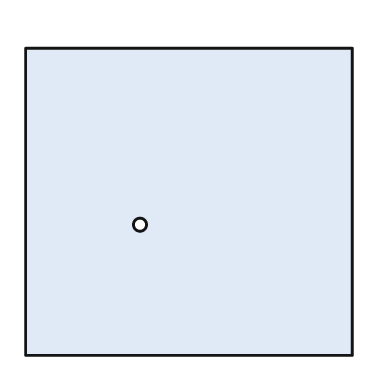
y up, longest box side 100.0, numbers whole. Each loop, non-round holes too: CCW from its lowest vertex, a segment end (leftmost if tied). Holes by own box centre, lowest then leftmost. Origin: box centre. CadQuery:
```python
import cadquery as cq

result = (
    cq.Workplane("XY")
    .moveTo(-50.0, -47.0)
    .lineTo(50.0, -47.0)
    .lineTo(50.0, 47.0)
    .lineTo(-50.0, 47.0)
    .close()
    .moveTo(-15.0, -7.0)
    .circle(2.0)
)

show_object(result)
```